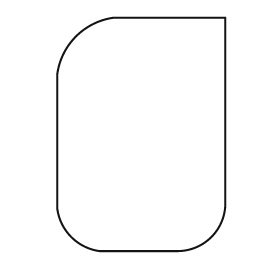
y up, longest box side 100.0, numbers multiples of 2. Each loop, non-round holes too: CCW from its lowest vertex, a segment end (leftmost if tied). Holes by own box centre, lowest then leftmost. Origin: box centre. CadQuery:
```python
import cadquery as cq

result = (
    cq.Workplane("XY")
    .moveTo(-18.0, -50.0)
    .lineTo(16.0, -50.0)
    .threePointArc((30.0, -44.0), (36.0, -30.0))
    .lineTo(36.0, 50.0)
    .lineTo(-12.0, 50.0)
    .threePointArc((-28.0, 42.0), (-36.0, 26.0))
    .lineTo(-36.0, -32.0)
    .threePointArc((-30.0, -44.0), (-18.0, -50.0))
    .close()
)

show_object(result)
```